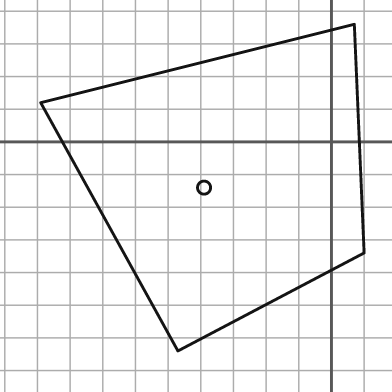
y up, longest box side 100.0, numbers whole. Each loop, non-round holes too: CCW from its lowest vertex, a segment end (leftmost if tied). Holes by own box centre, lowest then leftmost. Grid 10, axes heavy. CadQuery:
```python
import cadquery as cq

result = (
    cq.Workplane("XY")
    .moveTo(-47.0, -64.0)
    .lineTo(10.0, -34.0)
    .lineTo(7.0, 36.0)
    .lineTo(-89.0, 12.0)
    .close()
    .moveTo(-39.0, -14.0)
    .circle(2.0)
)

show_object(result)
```